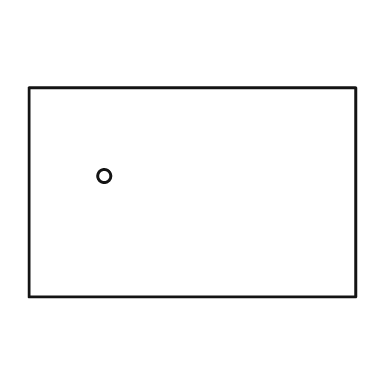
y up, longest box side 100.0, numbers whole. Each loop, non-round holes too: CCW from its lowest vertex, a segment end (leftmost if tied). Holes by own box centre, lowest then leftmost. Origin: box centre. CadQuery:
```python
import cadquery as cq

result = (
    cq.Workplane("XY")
    .moveTo(-50.0, -32.0)
    .lineTo(50.0, -32.0)
    .lineTo(50.0, 32.0)
    .lineTo(-50.0, 32.0)
    .close()
    .moveTo(-27.0, 5.0)
    .circle(2.0)
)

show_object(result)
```